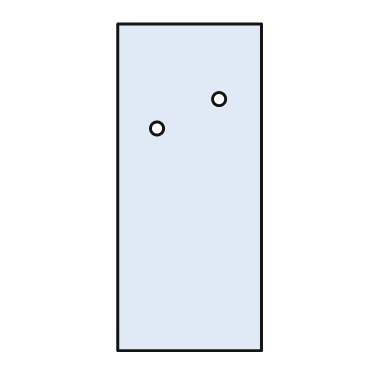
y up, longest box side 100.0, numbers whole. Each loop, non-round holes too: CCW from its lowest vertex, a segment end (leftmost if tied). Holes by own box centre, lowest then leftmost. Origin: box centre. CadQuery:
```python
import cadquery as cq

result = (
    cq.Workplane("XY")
    .moveTo(-22.0, -50.0)
    .lineTo(22.0, -50.0)
    .lineTo(22.0, 50.0)
    .lineTo(-22.0, 50.0)
    .close()
    .moveTo(-10.0, 18.0)
    .circle(2.0)
    .moveTo(9.0, 27.0)
    .circle(2.0)
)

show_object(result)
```